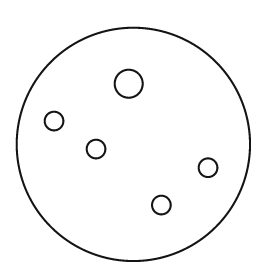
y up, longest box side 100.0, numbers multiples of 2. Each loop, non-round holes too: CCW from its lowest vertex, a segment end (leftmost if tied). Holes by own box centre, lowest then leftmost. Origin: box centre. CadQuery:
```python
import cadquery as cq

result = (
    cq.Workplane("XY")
    .moveTo(0.0, 0.0)
    .circle(50.0)
    .moveTo(12.0, -26.0)
    .circle(4.0)
    .moveTo(32.0, -10.0)
    .circle(4.0)
    .moveTo(-16.0, -2.0)
    .circle(4.0)
    .moveTo(-34.0, 10.0)
    .circle(4.0)
    .moveTo(-2.0, 26.0)
    .circle(6.0)
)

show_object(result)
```